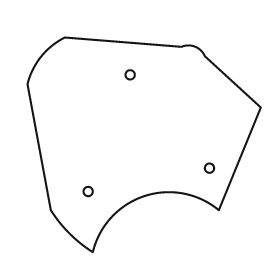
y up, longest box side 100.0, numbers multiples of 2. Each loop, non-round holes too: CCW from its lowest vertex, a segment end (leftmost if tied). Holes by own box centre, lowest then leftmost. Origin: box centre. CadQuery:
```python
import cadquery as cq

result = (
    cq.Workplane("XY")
    .moveTo(-22.0, -46.0)
    .threePointArc((0.0, -22.0), (32.0, -28.0))
    .lineTo(50.0, 16.0)
    .lineTo(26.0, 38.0)
    .threePointArc((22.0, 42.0), (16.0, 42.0))
    .lineTo(-34.0, 46.0)
    .threePointArc((-44.0, 38.0), (-50.0, 26.0))
    .lineTo(-40.0, -28.0)
    .threePointArc((-32.0, -38.0), (-22.0, -46.0))
    .close()
    .moveTo(-24.0, -20.0)
    .circle(2.0)
    .moveTo(28.0, -10.0)
    .circle(2.0)
    .moveTo(-6.0, 30.0)
    .circle(2.0)
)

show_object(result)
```